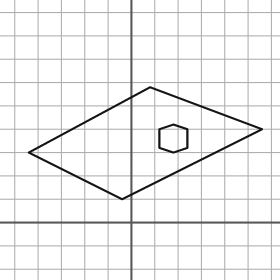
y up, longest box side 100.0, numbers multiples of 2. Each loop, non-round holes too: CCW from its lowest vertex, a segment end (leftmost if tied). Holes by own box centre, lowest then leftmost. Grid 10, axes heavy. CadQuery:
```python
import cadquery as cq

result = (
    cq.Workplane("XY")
    .moveTo(-4.0, 10.0)
    .lineTo(56.0, 40.0)
    .lineTo(8.0, 58.0)
    .lineTo(-44.0, 30.0)
    .close()
    .moveTo(18.0, 30.0)
    .lineTo(24.0, 32.0)
    .lineTo(24.0, 40.0)
    .lineTo(18.0, 42.0)
    .lineTo(12.0, 40.0)
    .lineTo(12.0, 32.0)
    .close()
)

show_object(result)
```